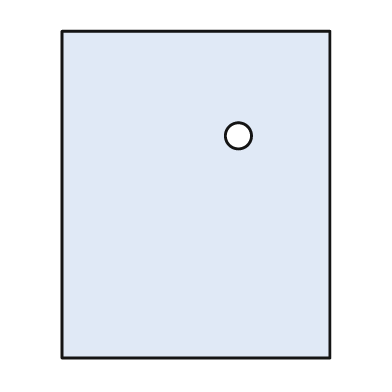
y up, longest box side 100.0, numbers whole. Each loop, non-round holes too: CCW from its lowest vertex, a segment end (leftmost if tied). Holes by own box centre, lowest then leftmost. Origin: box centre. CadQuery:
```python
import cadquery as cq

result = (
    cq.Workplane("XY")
    .moveTo(-41.0, -50.0)
    .lineTo(41.0, -50.0)
    .lineTo(41.0, 50.0)
    .lineTo(-41.0, 50.0)
    .close()
    .moveTo(13.0, 18.0)
    .circle(4.0)
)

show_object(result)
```